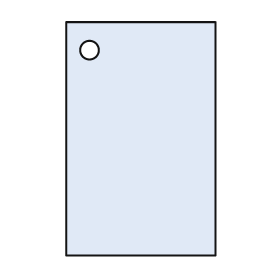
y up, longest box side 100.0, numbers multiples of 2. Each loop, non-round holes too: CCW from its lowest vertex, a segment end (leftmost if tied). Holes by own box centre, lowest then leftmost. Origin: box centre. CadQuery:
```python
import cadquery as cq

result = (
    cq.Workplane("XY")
    .moveTo(-32.0, -50.0)
    .lineTo(32.0, -50.0)
    .lineTo(32.0, 50.0)
    .lineTo(-32.0, 50.0)
    .close()
    .moveTo(-22.0, 38.0)
    .circle(4.0)
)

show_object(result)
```